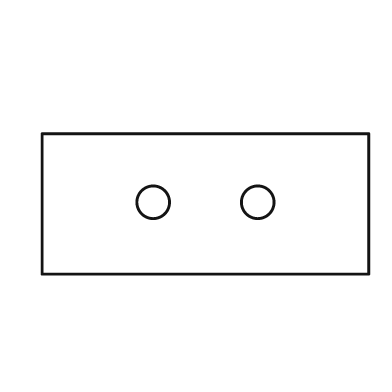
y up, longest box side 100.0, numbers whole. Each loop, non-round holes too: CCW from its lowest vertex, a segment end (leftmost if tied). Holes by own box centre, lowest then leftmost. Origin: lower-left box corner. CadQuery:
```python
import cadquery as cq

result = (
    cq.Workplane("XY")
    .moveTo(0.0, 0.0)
    .lineTo(100.0, 0.0)
    .lineTo(100.0, 43.0)
    .lineTo(0.0, 43.0)
    .close()
    .moveTo(34.0, 22.0)
    .circle(5.0)
    .moveTo(66.0, 22.0)
    .circle(5.0)
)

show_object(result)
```